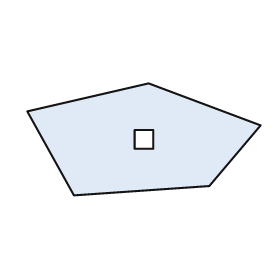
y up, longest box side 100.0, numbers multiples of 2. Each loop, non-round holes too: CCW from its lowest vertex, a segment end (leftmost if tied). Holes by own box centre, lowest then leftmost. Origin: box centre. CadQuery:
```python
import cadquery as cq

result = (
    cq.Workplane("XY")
    .moveTo(-30.0, -24.0)
    .lineTo(28.0, -20.0)
    .lineTo(50.0, 6.0)
    .lineTo(2.0, 24.0)
    .lineTo(-50.0, 12.0)
    .close()
    .moveTo(-4.0, -4.0)
    .lineTo(4.0, -4.0)
    .lineTo(4.0, 4.0)
    .lineTo(-4.0, 4.0)
    .close()
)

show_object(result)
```